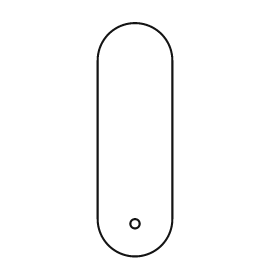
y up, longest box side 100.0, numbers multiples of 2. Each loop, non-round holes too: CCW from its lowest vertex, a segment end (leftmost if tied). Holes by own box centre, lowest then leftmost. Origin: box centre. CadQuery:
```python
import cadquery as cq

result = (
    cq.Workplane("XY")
    .moveTo(-16.0, -34.0)
    .threePointArc((0.0, -50.0), (16.0, -34.0))
    .lineTo(16.0, 34.0)
    .threePointArc((0.0, 50.0), (-16.0, 34.0))
    .close()
    .moveTo(0.0, -36.0)
    .circle(2.0)
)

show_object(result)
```